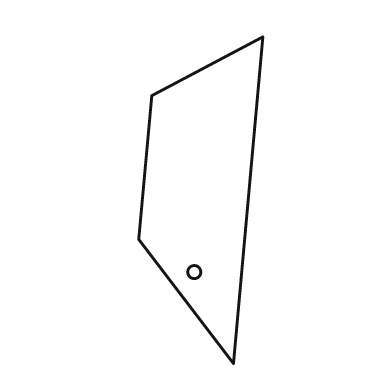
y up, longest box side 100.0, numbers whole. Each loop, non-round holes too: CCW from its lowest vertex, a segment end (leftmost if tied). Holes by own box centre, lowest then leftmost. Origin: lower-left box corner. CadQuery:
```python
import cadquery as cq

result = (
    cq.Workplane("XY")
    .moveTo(29.0, 0.0)
    .lineTo(38.0, 100.0)
    .lineTo(4.0, 82.0)
    .lineTo(0.0, 38.0)
    .close()
    .moveTo(17.0, 28.0)
    .circle(2.0)
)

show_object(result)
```